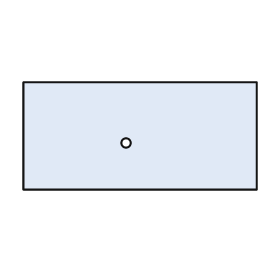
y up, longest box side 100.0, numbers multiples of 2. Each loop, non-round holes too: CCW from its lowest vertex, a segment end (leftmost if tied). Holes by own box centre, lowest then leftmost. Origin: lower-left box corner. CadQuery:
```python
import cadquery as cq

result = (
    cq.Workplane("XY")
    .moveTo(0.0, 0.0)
    .lineTo(100.0, 0.0)
    .lineTo(100.0, 46.0)
    .lineTo(0.0, 46.0)
    .close()
    .moveTo(44.0, 20.0)
    .circle(2.0)
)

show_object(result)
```